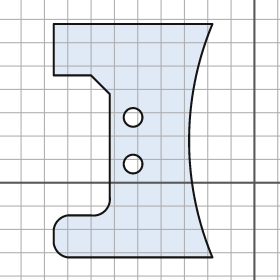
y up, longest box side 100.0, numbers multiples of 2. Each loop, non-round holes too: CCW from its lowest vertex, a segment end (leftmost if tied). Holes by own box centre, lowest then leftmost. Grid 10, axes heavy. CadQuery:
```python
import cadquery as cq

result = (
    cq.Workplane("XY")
    .moveTo(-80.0, -32.0)
    .lineTo(-18.0, -32.0)
    .threePointArc((-28.0, 18.0), (-18.0, 68.0))
    .lineTo(-86.0, 68.0)
    .lineTo(-86.0, 46.0)
    .lineTo(-70.0, 46.0)
    .lineTo(-62.0, 38.0)
    .lineTo(-62.0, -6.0)
    .threePointArc((-64.0, -12.0), (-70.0, -14.0))
    .lineTo(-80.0, -14.0)
    .threePointArc((-84.0, -16.0), (-86.0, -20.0))
    .lineTo(-86.0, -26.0)
    .threePointArc((-84.0, -30.0), (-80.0, -32.0))
    .close()
    .moveTo(-52.0, 8.0)
    .circle(4.0)
    .moveTo(-52.0, 28.0)
    .circle(4.0)
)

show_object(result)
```